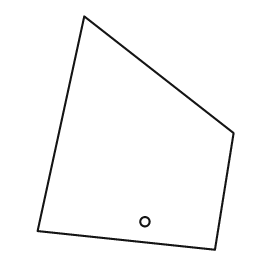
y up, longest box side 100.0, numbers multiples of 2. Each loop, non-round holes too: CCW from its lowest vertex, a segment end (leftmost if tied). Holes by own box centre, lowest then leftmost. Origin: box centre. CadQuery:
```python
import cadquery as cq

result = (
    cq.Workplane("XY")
    .moveTo(34.0, -50.0)
    .lineTo(42.0, 0.0)
    .lineTo(-22.0, 50.0)
    .lineTo(-42.0, -42.0)
    .close()
    .moveTo(4.0, -38.0)
    .circle(2.0)
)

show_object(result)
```